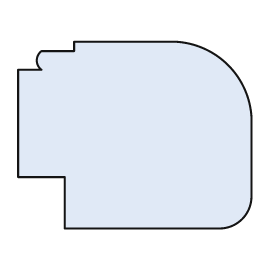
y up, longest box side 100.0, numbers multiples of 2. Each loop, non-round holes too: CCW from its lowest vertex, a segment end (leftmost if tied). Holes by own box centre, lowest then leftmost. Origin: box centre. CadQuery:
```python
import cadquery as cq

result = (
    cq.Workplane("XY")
    .moveTo(-30.0, -40.0)
    .lineTo(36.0, -40.0)
    .threePointArc((46.0, -36.0), (50.0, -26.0))
    .lineTo(50.0, 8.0)
    .threePointArc((40.0, 30.0), (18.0, 40.0))
    .lineTo(-26.0, 40.0)
    .lineTo(-26.0, 36.0)
    .lineTo(-40.0, 36.0)
    .threePointArc((-42.0, 32.0), (-40.0, 28.0))
    .lineTo(-50.0, 28.0)
    .lineTo(-50.0, -18.0)
    .lineTo(-30.0, -18.0)
    .close()
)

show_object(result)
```